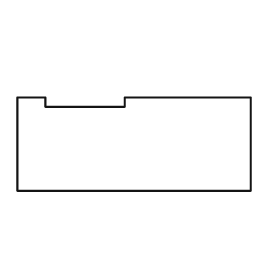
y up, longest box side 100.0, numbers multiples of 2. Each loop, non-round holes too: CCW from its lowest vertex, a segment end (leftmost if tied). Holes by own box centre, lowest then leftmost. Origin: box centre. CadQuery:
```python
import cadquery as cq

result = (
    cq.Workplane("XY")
    .moveTo(-50.0, -20.0)
    .lineTo(50.0, -20.0)
    .lineTo(50.0, 20.0)
    .lineTo(-4.0, 20.0)
    .lineTo(-4.0, 16.0)
    .lineTo(-38.0, 16.0)
    .lineTo(-38.0, 20.0)
    .lineTo(-50.0, 20.0)
    .close()
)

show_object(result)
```